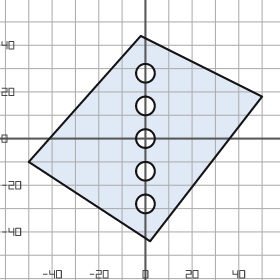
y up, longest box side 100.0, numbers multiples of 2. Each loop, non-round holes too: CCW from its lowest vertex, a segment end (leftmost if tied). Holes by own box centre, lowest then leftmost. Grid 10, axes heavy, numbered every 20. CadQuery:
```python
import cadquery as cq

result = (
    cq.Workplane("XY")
    .moveTo(2.0, -44.0)
    .lineTo(50.0, 18.0)
    .lineTo(-2.0, 44.0)
    .lineTo(-50.0, -10.0)
    .close()
    .moveTo(0.0, -28.0)
    .circle(4.0)
    .moveTo(0.0, -14.0)
    .circle(4.0)
    .moveTo(0.0, 0.0)
    .circle(4.0)
    .moveTo(0.0, 14.0)
    .circle(4.0)
    .moveTo(0.0, 28.0)
    .circle(4.0)
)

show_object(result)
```